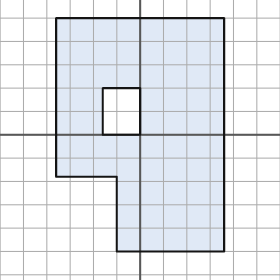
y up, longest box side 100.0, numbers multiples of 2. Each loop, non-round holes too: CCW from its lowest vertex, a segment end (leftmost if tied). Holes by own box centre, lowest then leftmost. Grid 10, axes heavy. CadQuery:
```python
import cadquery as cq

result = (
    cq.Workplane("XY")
    .moveTo(-10.0, -50.0)
    .lineTo(36.0, -50.0)
    .lineTo(36.0, 50.0)
    .lineTo(-36.0, 50.0)
    .lineTo(-36.0, -18.0)
    .lineTo(-10.0, -18.0)
    .close()
    .moveTo(-16.0, 0.0)
    .lineTo(0.0, 0.0)
    .lineTo(0.0, 20.0)
    .lineTo(-16.0, 20.0)
    .close()
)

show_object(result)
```